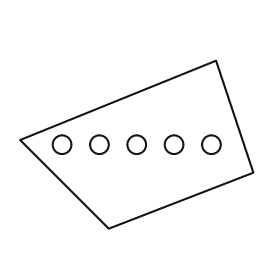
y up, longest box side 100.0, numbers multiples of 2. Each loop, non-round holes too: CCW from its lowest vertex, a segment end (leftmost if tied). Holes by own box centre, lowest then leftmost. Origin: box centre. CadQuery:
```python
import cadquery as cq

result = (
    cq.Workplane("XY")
    .moveTo(-12.0, -36.0)
    .lineTo(50.0, -12.0)
    .lineTo(34.0, 36.0)
    .lineTo(-50.0, 2.0)
    .close()
    .moveTo(-32.0, 0.0)
    .circle(4.0)
    .moveTo(-16.0, 0.0)
    .circle(4.0)
    .moveTo(0.0, 0.0)
    .circle(4.0)
    .moveTo(16.0, 0.0)
    .circle(4.0)
    .moveTo(32.0, 0.0)
    .circle(4.0)
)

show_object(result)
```